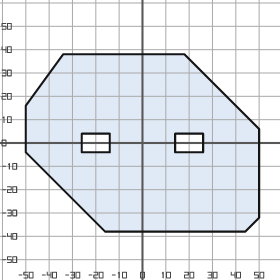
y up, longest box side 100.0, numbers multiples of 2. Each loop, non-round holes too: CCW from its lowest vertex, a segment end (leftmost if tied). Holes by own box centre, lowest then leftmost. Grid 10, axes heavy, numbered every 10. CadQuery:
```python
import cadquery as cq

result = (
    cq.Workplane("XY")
    .moveTo(-16.0, -38.0)
    .lineTo(44.0, -38.0)
    .lineTo(50.0, -32.0)
    .lineTo(50.0, 6.0)
    .lineTo(18.0, 38.0)
    .lineTo(-34.0, 38.0)
    .lineTo(-50.0, 16.0)
    .lineTo(-50.0, -4.0)
    .close()
    .moveTo(-26.0, -4.0)
    .lineTo(-14.0, -4.0)
    .lineTo(-14.0, 4.0)
    .lineTo(-26.0, 4.0)
    .close()
    .moveTo(14.0, -4.0)
    .lineTo(26.0, -4.0)
    .lineTo(26.0, 4.0)
    .lineTo(14.0, 4.0)
    .close()
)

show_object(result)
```